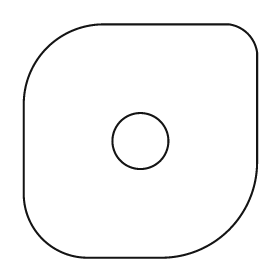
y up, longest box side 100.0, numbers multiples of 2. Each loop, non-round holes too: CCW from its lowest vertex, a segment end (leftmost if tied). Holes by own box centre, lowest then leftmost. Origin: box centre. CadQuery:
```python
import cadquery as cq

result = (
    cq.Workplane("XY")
    .moveTo(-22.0, -50.0)
    .lineTo(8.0, -50.0)
    .threePointArc((38.0, -38.0), (50.0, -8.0))
    .lineTo(50.0, 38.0)
    .threePointArc((46.0, 46.0), (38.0, 50.0))
    .lineTo(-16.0, 50.0)
    .threePointArc((-40.0, 40.0), (-50.0, 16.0))
    .lineTo(-50.0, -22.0)
    .threePointArc((-42.0, -42.0), (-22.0, -50.0))
    .close()
    .moveTo(0.0, 0.0)
    .circle(12.0)
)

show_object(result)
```